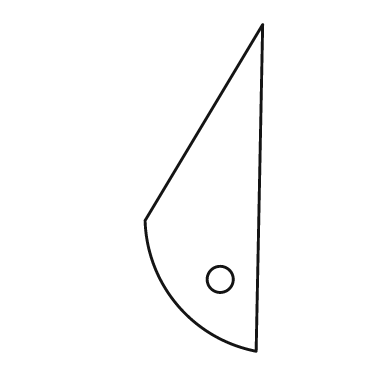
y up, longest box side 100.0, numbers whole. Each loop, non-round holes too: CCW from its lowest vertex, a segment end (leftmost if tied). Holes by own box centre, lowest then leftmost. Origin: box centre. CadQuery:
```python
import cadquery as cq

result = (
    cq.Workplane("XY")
    .moveTo(16.0, -50.0)
    .lineTo(18.0, 50.0)
    .lineTo(-18.0, -10.0)
    .threePointArc((-8.0, -36.0), (16.0, -50.0))
    .close()
    .moveTo(5.0, -28.0)
    .circle(4.0)
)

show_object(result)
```